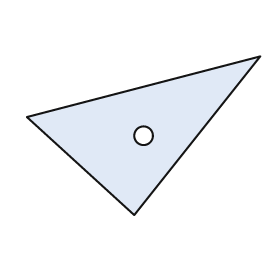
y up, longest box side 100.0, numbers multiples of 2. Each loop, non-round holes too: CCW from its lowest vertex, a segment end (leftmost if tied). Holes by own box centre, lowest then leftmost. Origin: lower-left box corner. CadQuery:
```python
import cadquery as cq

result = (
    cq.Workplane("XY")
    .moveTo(46.0, 0.0)
    .lineTo(100.0, 68.0)
    .lineTo(0.0, 42.0)
    .close()
    .moveTo(50.0, 34.0)
    .circle(4.0)
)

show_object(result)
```